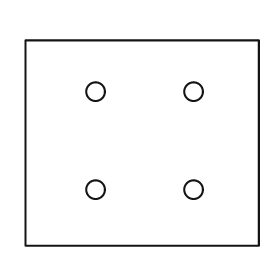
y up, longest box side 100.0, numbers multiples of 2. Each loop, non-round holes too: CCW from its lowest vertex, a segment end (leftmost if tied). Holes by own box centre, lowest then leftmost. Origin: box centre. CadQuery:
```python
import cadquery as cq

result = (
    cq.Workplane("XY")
    .moveTo(-50.0, -44.0)
    .lineTo(50.0, -44.0)
    .lineTo(50.0, 44.0)
    .lineTo(-50.0, 44.0)
    .close()
    .moveTo(-20.0, -20.0)
    .circle(4.0)
    .moveTo(22.0, -20.0)
    .circle(4.0)
    .moveTo(-20.0, 22.0)
    .circle(4.0)
    .moveTo(22.0, 22.0)
    .circle(4.0)
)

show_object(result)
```